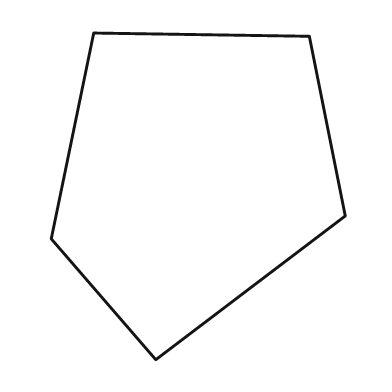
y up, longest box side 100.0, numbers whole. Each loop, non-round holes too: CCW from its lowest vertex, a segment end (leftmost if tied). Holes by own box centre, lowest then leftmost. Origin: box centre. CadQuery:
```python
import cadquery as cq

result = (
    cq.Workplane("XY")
    .moveTo(-13.0, -50.0)
    .lineTo(45.0, -6.0)
    .lineTo(34.0, 49.0)
    .lineTo(-32.0, 50.0)
    .lineTo(-45.0, -13.0)
    .close()
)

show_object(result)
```